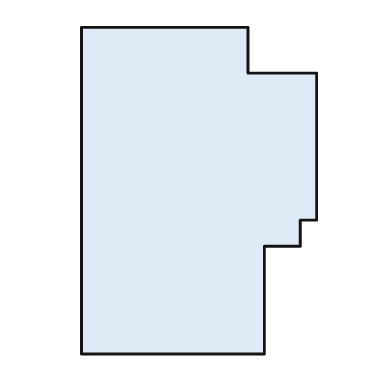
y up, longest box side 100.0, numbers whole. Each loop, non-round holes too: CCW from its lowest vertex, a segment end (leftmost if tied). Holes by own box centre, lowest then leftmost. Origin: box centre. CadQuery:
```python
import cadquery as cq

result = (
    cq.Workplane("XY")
    .moveTo(-36.0, -50.0)
    .lineTo(20.0, -50.0)
    .lineTo(20.0, -17.0)
    .lineTo(31.0, -17.0)
    .lineTo(31.0, -9.0)
    .lineTo(36.0, -9.0)
    .lineTo(36.0, 36.0)
    .lineTo(15.0, 36.0)
    .lineTo(15.0, 50.0)
    .lineTo(-36.0, 50.0)
    .close()
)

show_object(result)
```